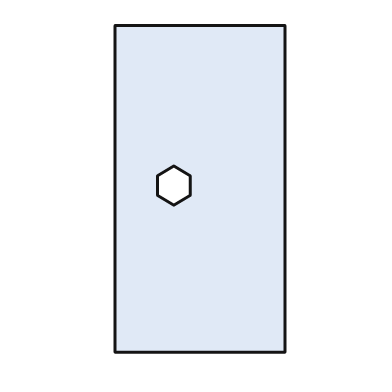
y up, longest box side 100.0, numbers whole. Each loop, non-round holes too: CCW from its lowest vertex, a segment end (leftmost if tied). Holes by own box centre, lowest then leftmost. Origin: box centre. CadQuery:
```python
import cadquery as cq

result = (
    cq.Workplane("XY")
    .moveTo(-26.0, -50.0)
    .lineTo(26.0, -50.0)
    .lineTo(26.0, 50.0)
    .lineTo(-26.0, 50.0)
    .close()
    .moveTo(-8.0, -5.0)
    .lineTo(-3.0, -2.0)
    .lineTo(-3.0, 4.0)
    .lineTo(-8.0, 7.0)
    .lineTo(-13.0, 4.0)
    .lineTo(-13.0, -2.0)
    .close()
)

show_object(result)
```